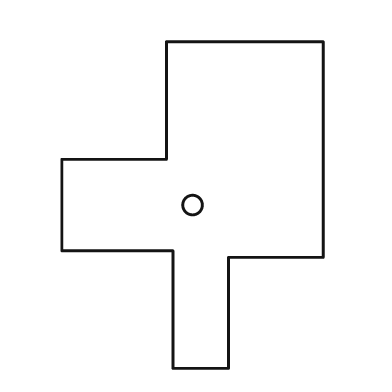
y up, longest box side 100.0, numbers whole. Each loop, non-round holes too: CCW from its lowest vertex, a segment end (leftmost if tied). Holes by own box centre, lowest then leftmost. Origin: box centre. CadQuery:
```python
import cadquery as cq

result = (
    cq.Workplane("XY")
    .moveTo(-6.0, -50.0)
    .lineTo(11.0, -50.0)
    .lineTo(11.0, -16.0)
    .lineTo(40.0, -16.0)
    .lineTo(40.0, 50.0)
    .lineTo(-8.0, 50.0)
    .lineTo(-8.0, 14.0)
    .lineTo(-40.0, 14.0)
    .lineTo(-40.0, -14.0)
    .lineTo(-6.0, -14.0)
    .close()
    .moveTo(0.0, 0.0)
    .circle(3.0)
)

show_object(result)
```